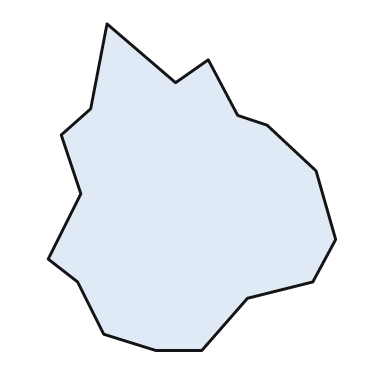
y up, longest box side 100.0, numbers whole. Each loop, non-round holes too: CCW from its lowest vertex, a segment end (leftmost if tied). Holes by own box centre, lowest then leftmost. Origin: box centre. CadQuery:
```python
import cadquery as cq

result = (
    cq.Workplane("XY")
    .moveTo(-11.0, -50.0)
    .lineTo(3.0, -50.0)
    .lineTo(17.0, -34.0)
    .lineTo(37.0, -29.0)
    .lineTo(44.0, -16.0)
    .lineTo(38.0, 5.0)
    .lineTo(23.0, 19.0)
    .lineTo(14.0, 22.0)
    .lineTo(5.0, 39.0)
    .lineTo(-5.0, 32.0)
    .lineTo(-26.0, 50.0)
    .lineTo(-31.0, 24.0)
    .lineTo(-40.0, 16.0)
    .lineTo(-34.0, -2.0)
    .lineTo(-44.0, -22.0)
    .lineTo(-35.0, -29.0)
    .lineTo(-27.0, -45.0)
    .close()
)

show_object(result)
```